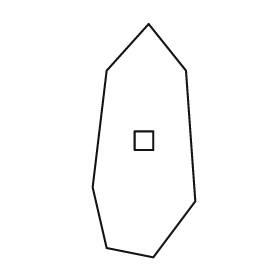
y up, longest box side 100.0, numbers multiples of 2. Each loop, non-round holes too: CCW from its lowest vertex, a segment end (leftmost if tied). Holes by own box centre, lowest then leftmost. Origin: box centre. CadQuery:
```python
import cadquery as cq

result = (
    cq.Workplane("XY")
    .moveTo(4.0, -50.0)
    .lineTo(22.0, -26.0)
    .lineTo(18.0, 30.0)
    .lineTo(2.0, 50.0)
    .lineTo(-16.0, 30.0)
    .lineTo(-22.0, -20.0)
    .lineTo(-16.0, -46.0)
    .close()
    .moveTo(-4.0, -4.0)
    .lineTo(4.0, -4.0)
    .lineTo(4.0, 4.0)
    .lineTo(-4.0, 4.0)
    .close()
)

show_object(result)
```